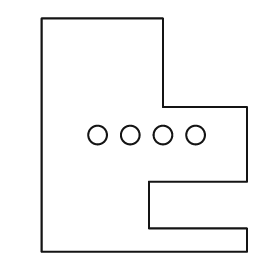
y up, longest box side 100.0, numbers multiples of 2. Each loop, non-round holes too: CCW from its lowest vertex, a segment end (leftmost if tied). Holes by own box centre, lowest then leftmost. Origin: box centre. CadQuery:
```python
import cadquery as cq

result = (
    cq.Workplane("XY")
    .moveTo(-44.0, -50.0)
    .lineTo(44.0, -50.0)
    .lineTo(44.0, -40.0)
    .lineTo(2.0, -40.0)
    .lineTo(2.0, -20.0)
    .lineTo(44.0, -20.0)
    .lineTo(44.0, 12.0)
    .lineTo(8.0, 12.0)
    .lineTo(8.0, 50.0)
    .lineTo(-44.0, 50.0)
    .close()
    .moveTo(-20.0, 0.0)
    .circle(4.0)
    .moveTo(-6.0, 0.0)
    .circle(4.0)
    .moveTo(8.0, 0.0)
    .circle(4.0)
    .moveTo(22.0, 0.0)
    .circle(4.0)
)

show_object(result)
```